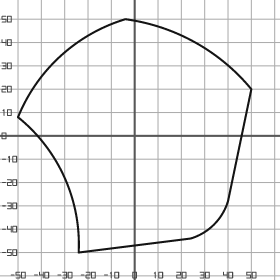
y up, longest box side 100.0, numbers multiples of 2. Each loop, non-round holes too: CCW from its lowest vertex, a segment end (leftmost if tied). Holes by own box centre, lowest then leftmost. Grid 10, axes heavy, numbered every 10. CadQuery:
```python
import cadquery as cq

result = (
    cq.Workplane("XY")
    .moveTo(-24.0, -50.0)
    .lineTo(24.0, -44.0)
    .threePointArc((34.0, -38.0), (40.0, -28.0))
    .lineTo(50.0, 20.0)
    .threePointArc((26.0, 40.0), (-4.0, 50.0))
    .threePointArc((-32.0, 34.0), (-50.0, 8.0))
    .threePointArc((-30.0, -18.0), (-24.0, -50.0))
    .close()
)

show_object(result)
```